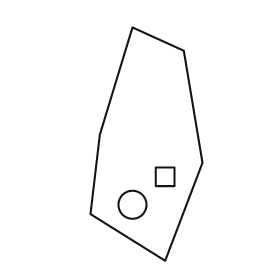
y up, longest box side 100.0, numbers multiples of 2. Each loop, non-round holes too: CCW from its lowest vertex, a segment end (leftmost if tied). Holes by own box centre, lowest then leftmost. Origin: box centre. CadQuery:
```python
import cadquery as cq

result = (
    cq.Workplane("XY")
    .moveTo(8.0, -50.0)
    .lineTo(24.0, -8.0)
    .lineTo(16.0, 40.0)
    .lineTo(-6.0, 50.0)
    .lineTo(-20.0, 4.0)
    .lineTo(-24.0, -30.0)
    .close()
    .moveTo(-6.0, -26.0)
    .circle(6.0)
    .moveTo(4.0, -18.0)
    .lineTo(12.0, -18.0)
    .lineTo(12.0, -10.0)
    .lineTo(4.0, -10.0)
    .close()
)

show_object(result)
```